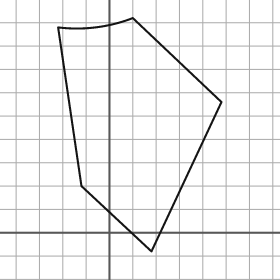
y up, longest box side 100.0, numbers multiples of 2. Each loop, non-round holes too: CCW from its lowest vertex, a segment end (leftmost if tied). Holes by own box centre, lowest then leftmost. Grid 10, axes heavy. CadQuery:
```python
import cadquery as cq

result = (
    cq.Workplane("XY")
    .moveTo(18.0, -8.0)
    .lineTo(48.0, 56.0)
    .lineTo(10.0, 92.0)
    .threePointArc((-6.0, 88.0), (-22.0, 88.0))
    .lineTo(-12.0, 20.0)
    .close()
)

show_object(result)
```